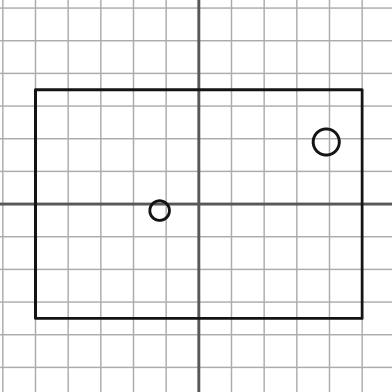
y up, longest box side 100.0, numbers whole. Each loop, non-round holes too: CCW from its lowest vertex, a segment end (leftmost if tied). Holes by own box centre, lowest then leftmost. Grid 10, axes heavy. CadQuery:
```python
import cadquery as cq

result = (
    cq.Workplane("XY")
    .moveTo(-50.0, -35.0)
    .lineTo(50.0, -35.0)
    .lineTo(50.0, 35.0)
    .lineTo(-50.0, 35.0)
    .close()
    .moveTo(-12.0, -2.0)
    .circle(3.0)
    .moveTo(39.0, 19.0)
    .circle(4.0)
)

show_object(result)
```